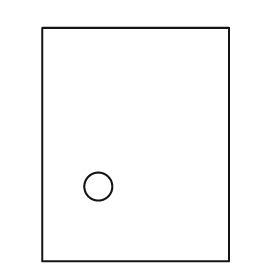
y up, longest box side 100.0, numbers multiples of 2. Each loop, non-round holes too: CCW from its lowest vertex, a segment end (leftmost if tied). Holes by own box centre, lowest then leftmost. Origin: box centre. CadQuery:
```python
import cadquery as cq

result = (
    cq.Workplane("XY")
    .moveTo(-40.0, -50.0)
    .lineTo(40.0, -50.0)
    .lineTo(40.0, 50.0)
    .lineTo(-40.0, 50.0)
    .close()
    .moveTo(-16.0, -18.0)
    .circle(6.0)
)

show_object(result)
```